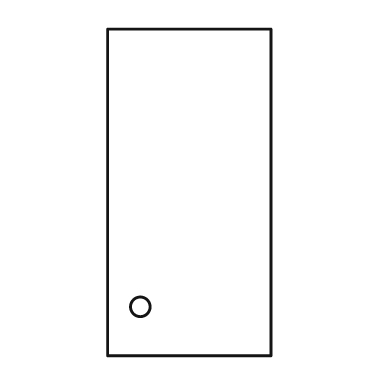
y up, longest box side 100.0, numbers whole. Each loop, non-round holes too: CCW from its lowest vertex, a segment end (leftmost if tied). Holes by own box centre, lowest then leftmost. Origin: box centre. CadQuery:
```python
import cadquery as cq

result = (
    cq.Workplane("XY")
    .moveTo(-25.0, -50.0)
    .lineTo(25.0, -50.0)
    .lineTo(25.0, 50.0)
    .lineTo(-25.0, 50.0)
    .close()
    .moveTo(-15.0, -35.0)
    .circle(3.0)
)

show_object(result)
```